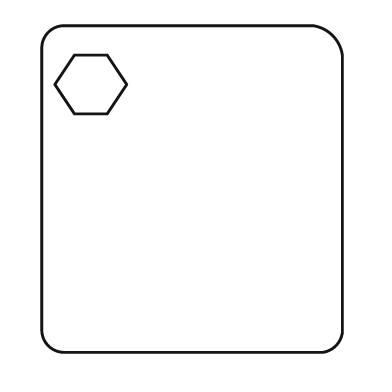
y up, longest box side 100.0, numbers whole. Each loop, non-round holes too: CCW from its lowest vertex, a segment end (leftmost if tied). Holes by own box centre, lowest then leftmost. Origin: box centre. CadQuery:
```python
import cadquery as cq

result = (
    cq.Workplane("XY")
    .moveTo(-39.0, -50.0)
    .lineTo(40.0, -50.0)
    .threePointArc((44.0, -48.0), (46.0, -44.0))
    .lineTo(46.0, 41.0)
    .threePointArc((43.0, 47.0), (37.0, 50.0))
    .lineTo(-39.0, 50.0)
    .threePointArc((-44.0, 48.0), (-46.0, 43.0))
    .lineTo(-46.0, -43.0)
    .threePointArc((-44.0, -48.0), (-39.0, -50.0))
    .close()
    .moveTo(-36.0, 23.0)
    .lineTo(-26.0, 23.0)
    .lineTo(-20.0, 32.0)
    .lineTo(-26.0, 41.0)
    .lineTo(-36.0, 41.0)
    .lineTo(-42.0, 32.0)
    .close()
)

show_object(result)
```